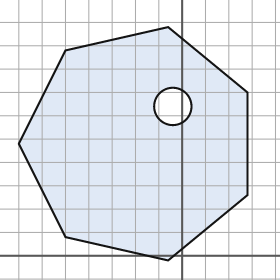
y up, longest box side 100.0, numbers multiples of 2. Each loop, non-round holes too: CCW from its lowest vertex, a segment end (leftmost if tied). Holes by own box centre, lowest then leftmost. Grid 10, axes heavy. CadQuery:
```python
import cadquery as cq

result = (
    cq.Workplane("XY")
    .moveTo(-6.0, -2.0)
    .lineTo(28.0, 26.0)
    .lineTo(28.0, 70.0)
    .lineTo(-6.0, 98.0)
    .lineTo(-50.0, 88.0)
    .lineTo(-70.0, 48.0)
    .lineTo(-50.0, 8.0)
    .close()
    .moveTo(-4.0, 64.0)
    .circle(8.0)
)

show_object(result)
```